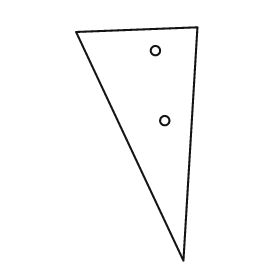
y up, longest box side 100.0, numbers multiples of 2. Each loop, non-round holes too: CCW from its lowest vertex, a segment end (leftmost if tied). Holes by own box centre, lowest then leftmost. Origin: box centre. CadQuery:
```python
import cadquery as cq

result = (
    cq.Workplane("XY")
    .moveTo(20.0, -50.0)
    .lineTo(26.0, 50.0)
    .lineTo(-26.0, 48.0)
    .close()
    .moveTo(12.0, 10.0)
    .circle(2.0)
    .moveTo(8.0, 40.0)
    .circle(2.0)
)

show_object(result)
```